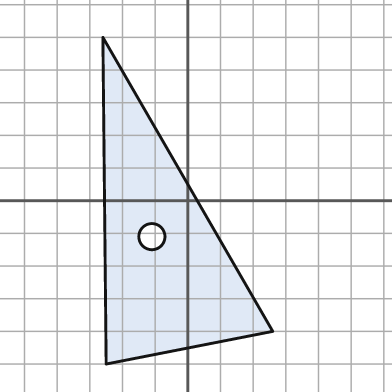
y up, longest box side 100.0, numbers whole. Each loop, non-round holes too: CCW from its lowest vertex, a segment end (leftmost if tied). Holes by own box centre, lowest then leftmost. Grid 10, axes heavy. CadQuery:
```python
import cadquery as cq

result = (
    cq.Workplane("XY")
    .moveTo(-25.0, -50.0)
    .lineTo(26.0, -40.0)
    .lineTo(-26.0, 50.0)
    .close()
    .moveTo(-11.0, -11.0)
    .circle(4.0)
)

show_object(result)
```